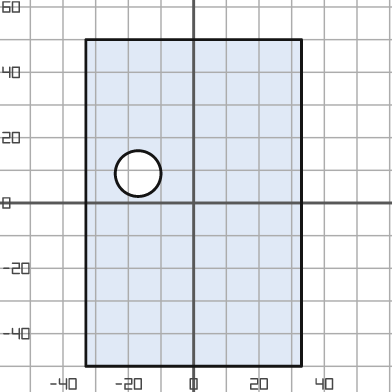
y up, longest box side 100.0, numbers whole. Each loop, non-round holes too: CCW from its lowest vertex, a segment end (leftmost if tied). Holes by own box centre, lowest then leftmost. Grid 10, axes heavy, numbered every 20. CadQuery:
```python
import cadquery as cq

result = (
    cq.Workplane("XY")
    .moveTo(-33.0, -50.0)
    .lineTo(33.0, -50.0)
    .lineTo(33.0, 50.0)
    .lineTo(-33.0, 50.0)
    .close()
    .moveTo(-17.0, 9.0)
    .circle(7.0)
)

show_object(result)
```